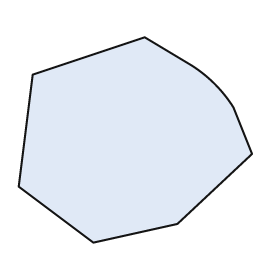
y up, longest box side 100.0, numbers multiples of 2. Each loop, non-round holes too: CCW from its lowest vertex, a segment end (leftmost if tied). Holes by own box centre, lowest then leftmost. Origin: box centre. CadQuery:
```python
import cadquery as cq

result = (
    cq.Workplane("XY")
    .moveTo(-18.0, -44.0)
    .lineTo(18.0, -36.0)
    .lineTo(50.0, -6.0)
    .lineTo(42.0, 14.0)
    .threePointArc((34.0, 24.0), (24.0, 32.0))
    .lineTo(4.0, 44.0)
    .lineTo(-44.0, 28.0)
    .lineTo(-50.0, -20.0)
    .close()
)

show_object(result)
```